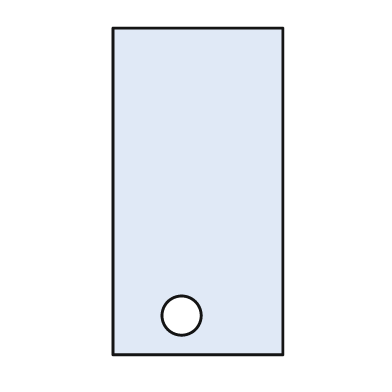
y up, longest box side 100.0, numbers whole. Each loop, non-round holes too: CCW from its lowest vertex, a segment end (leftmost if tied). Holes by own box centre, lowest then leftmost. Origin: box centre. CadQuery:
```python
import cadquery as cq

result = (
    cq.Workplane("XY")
    .moveTo(-26.0, -50.0)
    .lineTo(26.0, -50.0)
    .lineTo(26.0, 50.0)
    .lineTo(-26.0, 50.0)
    .close()
    .moveTo(-5.0, -38.0)
    .circle(6.0)
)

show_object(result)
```